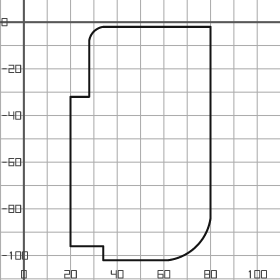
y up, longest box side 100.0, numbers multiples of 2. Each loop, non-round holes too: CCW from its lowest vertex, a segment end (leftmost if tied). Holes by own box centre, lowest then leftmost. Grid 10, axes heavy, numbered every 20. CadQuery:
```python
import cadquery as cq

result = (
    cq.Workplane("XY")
    .moveTo(34.0, -102.0)
    .lineTo(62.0, -102.0)
    .threePointArc((74.0, -96.0), (80.0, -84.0))
    .lineTo(80.0, -2.0)
    .lineTo(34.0, -2.0)
    .threePointArc((30.0, -4.0), (28.0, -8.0))
    .lineTo(28.0, -32.0)
    .lineTo(20.0, -32.0)
    .lineTo(20.0, -96.0)
    .lineTo(34.0, -96.0)
    .close()
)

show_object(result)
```